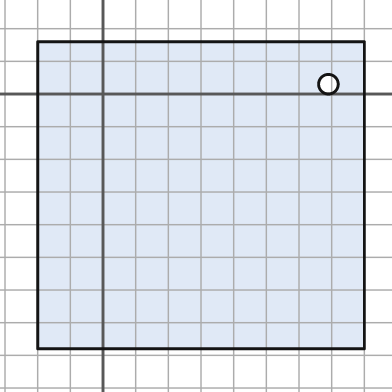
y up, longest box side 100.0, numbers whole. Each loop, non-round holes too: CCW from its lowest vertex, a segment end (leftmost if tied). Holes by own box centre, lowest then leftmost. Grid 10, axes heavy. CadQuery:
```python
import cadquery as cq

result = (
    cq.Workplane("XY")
    .moveTo(-20.0, -78.0)
    .lineTo(80.0, -78.0)
    .lineTo(80.0, 16.0)
    .lineTo(-20.0, 16.0)
    .close()
    .moveTo(69.0, 3.0)
    .circle(3.0)
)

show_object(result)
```